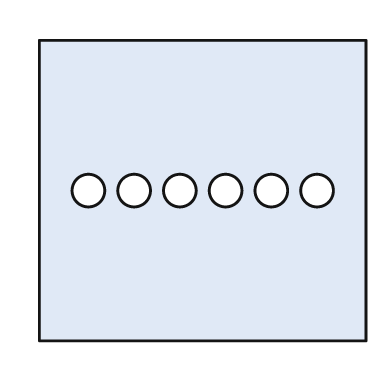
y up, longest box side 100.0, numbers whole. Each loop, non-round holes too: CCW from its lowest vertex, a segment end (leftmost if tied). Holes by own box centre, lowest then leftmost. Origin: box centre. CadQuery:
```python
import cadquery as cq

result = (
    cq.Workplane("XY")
    .moveTo(-50.0, -46.0)
    .lineTo(50.0, -46.0)
    .lineTo(50.0, 46.0)
    .lineTo(-50.0, 46.0)
    .close()
    .moveTo(-35.0, 0.0)
    .circle(5.0)
    .moveTo(-21.0, 0.0)
    .circle(5.0)
    .moveTo(-7.0, 0.0)
    .circle(5.0)
    .moveTo(7.0, 0.0)
    .circle(5.0)
    .moveTo(21.0, 0.0)
    .circle(5.0)
    .moveTo(35.0, 0.0)
    .circle(5.0)
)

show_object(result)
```